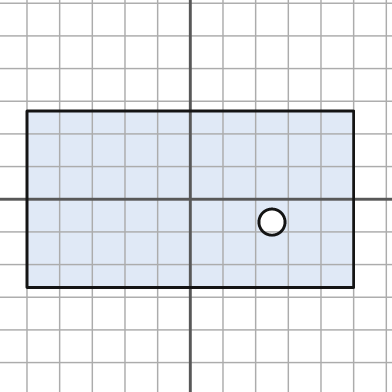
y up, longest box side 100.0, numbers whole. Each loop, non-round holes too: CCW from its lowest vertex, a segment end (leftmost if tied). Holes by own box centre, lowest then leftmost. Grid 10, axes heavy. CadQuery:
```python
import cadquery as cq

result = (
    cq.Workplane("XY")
    .moveTo(-50.0, -27.0)
    .lineTo(50.0, -27.0)
    .lineTo(50.0, 27.0)
    .lineTo(-50.0, 27.0)
    .close()
    .moveTo(25.0, -7.0)
    .circle(4.0)
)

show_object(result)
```